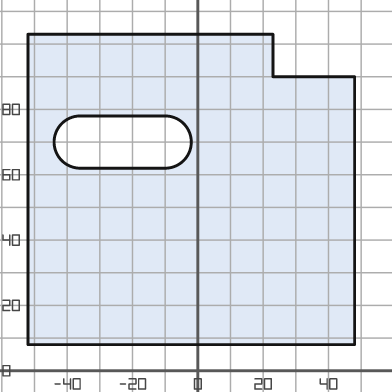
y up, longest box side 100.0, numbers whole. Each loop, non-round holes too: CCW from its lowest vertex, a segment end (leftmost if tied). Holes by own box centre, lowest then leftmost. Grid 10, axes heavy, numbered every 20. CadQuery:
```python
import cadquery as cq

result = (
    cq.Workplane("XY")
    .moveTo(-52.0, 8.0)
    .lineTo(48.0, 8.0)
    .lineTo(48.0, 90.0)
    .lineTo(23.0, 90.0)
    .lineTo(23.0, 103.0)
    .lineTo(-52.0, 103.0)
    .close()
    .moveTo(-36.0, 62.0)
    .lineTo(-10.0, 62.0)
    .threePointArc((-2.0, 70.0), (-10.0, 78.0))
    .lineTo(-36.0, 78.0)
    .threePointArc((-44.0, 70.0), (-36.0, 62.0))
    .close()
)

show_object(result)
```